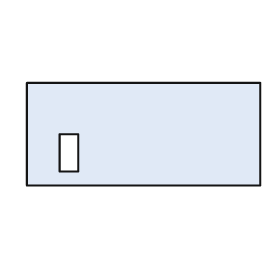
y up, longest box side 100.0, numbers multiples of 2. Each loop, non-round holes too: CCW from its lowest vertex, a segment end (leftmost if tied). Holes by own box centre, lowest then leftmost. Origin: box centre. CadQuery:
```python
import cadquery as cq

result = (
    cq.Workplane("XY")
    .moveTo(-50.0, -22.0)
    .lineTo(50.0, -22.0)
    .lineTo(50.0, 22.0)
    .lineTo(-50.0, 22.0)
    .close()
    .moveTo(-36.0, -16.0)
    .lineTo(-28.0, -16.0)
    .lineTo(-28.0, 0.0)
    .lineTo(-36.0, 0.0)
    .close()
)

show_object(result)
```